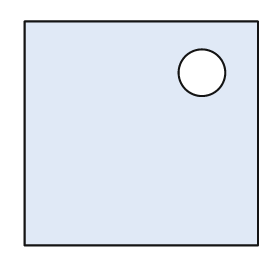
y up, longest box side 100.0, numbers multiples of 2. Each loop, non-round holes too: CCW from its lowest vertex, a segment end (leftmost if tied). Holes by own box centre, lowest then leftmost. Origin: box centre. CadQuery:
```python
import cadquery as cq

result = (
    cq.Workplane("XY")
    .moveTo(-50.0, -48.0)
    .lineTo(50.0, -48.0)
    .lineTo(50.0, 48.0)
    .lineTo(-50.0, 48.0)
    .close()
    .moveTo(26.0, 26.0)
    .circle(10.0)
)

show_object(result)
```